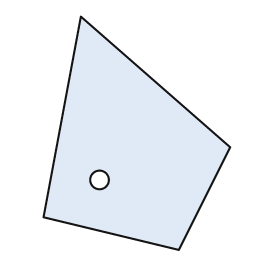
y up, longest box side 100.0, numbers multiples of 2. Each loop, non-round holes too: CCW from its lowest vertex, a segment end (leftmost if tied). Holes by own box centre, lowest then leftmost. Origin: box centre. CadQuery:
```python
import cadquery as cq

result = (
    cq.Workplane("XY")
    .moveTo(18.0, -50.0)
    .lineTo(40.0, -6.0)
    .lineTo(-24.0, 50.0)
    .lineTo(-40.0, -36.0)
    .close()
    .moveTo(-16.0, -20.0)
    .circle(4.0)
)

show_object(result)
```